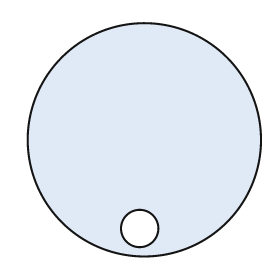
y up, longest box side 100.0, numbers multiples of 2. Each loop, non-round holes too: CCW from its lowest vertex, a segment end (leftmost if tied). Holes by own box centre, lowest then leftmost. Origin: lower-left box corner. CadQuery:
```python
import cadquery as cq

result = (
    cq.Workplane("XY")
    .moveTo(50.0, 50.0)
    .circle(50.0)
    .moveTo(48.0, 12.0)
    .circle(8.0)
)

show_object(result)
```